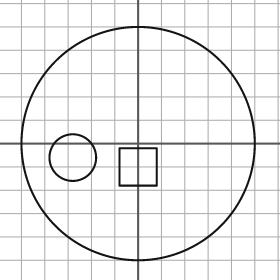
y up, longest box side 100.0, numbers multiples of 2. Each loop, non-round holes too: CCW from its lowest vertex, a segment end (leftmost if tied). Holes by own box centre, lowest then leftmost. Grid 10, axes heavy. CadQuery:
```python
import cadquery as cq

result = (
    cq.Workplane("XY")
    .moveTo(0.0, 0.0)
    .circle(50.0)
    .moveTo(-8.0, -18.0)
    .lineTo(8.0, -18.0)
    .lineTo(8.0, -2.0)
    .lineTo(-8.0, -2.0)
    .close()
    .moveTo(-28.0, -6.0)
    .circle(10.0)
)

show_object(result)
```